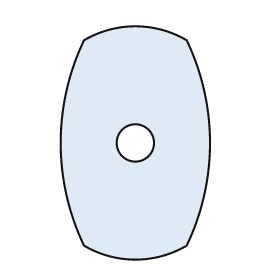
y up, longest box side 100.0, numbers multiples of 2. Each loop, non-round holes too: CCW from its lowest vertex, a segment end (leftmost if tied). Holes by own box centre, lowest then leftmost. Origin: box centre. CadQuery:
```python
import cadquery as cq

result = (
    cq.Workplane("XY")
    .moveTo(-22.0, -44.0)
    .threePointArc((0.0, -50.0), (22.0, -44.0))
    .threePointArc((32.0, 0.0), (22.0, 44.0))
    .threePointArc((0.0, 50.0), (-22.0, 44.0))
    .threePointArc((-32.0, 0.0), (-22.0, -44.0))
    .close()
    .moveTo(0.0, 0.0)
    .circle(8.0)
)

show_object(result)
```